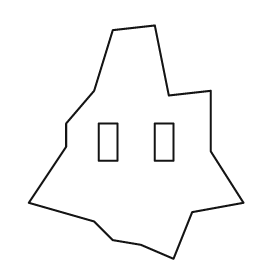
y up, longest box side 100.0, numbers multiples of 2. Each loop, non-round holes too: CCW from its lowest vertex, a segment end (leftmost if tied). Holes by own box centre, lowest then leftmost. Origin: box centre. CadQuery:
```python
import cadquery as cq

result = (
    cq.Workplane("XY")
    .moveTo(16.0, -50.0)
    .lineTo(24.0, -30.0)
    .lineTo(46.0, -26.0)
    .lineTo(32.0, -4.0)
    .lineTo(32.0, 22.0)
    .lineTo(14.0, 20.0)
    .lineTo(8.0, 50.0)
    .lineTo(-10.0, 48.0)
    .lineTo(-18.0, 22.0)
    .lineTo(-30.0, 8.0)
    .lineTo(-30.0, -2.0)
    .lineTo(-46.0, -26.0)
    .lineTo(-18.0, -34.0)
    .lineTo(-10.0, -42.0)
    .lineTo(2.0, -44.0)
    .close()
    .moveTo(-16.0, -8.0)
    .lineTo(-8.0, -8.0)
    .lineTo(-8.0, 8.0)
    .lineTo(-16.0, 8.0)
    .close()
    .moveTo(8.0, -8.0)
    .lineTo(16.0, -8.0)
    .lineTo(16.0, 8.0)
    .lineTo(8.0, 8.0)
    .close()
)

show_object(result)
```